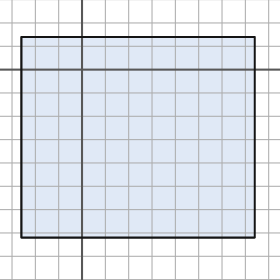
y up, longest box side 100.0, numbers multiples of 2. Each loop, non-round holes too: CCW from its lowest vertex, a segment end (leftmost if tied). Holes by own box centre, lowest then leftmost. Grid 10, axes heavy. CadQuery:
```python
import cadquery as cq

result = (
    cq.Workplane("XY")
    .moveTo(-26.0, -72.0)
    .lineTo(74.0, -72.0)
    .lineTo(74.0, 14.0)
    .lineTo(-26.0, 14.0)
    .close()
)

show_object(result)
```